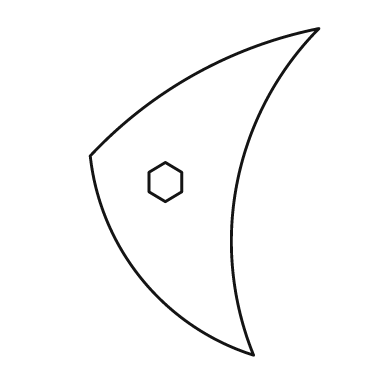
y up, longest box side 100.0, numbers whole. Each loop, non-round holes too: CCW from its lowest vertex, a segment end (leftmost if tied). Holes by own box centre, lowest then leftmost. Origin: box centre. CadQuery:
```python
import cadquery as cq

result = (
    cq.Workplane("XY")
    .moveTo(15.0, -50.0)
    .threePointArc((10.0, 3.0), (35.0, 50.0))
    .threePointArc((-3.0, 36.0), (-35.0, 11.0))
    .threePointArc((-19.0, -27.0), (15.0, -50.0))
    .close()
    .moveTo(-12.0, -3.0)
    .lineTo(-7.0, 0.0)
    .lineTo(-7.0, 6.0)
    .lineTo(-12.0, 9.0)
    .lineTo(-17.0, 6.0)
    .lineTo(-17.0, 0.0)
    .close()
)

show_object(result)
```